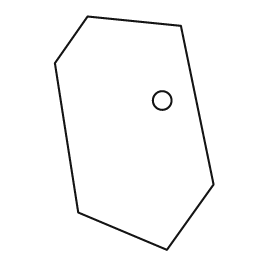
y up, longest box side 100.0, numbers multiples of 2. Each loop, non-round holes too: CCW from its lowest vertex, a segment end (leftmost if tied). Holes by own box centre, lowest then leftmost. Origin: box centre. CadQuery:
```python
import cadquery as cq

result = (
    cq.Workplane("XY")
    .moveTo(14.0, -50.0)
    .lineTo(34.0, -22.0)
    .lineTo(20.0, 46.0)
    .lineTo(-20.0, 50.0)
    .lineTo(-34.0, 30.0)
    .lineTo(-24.0, -34.0)
    .close()
    .moveTo(12.0, 14.0)
    .circle(4.0)
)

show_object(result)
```